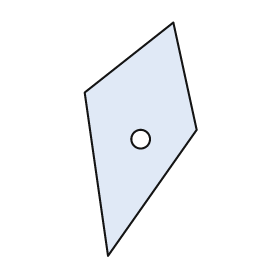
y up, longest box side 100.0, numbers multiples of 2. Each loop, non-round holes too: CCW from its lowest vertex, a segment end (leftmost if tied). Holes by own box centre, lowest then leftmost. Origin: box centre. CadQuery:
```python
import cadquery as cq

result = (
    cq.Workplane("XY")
    .moveTo(-14.0, -50.0)
    .lineTo(24.0, 4.0)
    .lineTo(14.0, 50.0)
    .lineTo(-24.0, 20.0)
    .close()
    .moveTo(0.0, 0.0)
    .circle(4.0)
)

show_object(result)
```